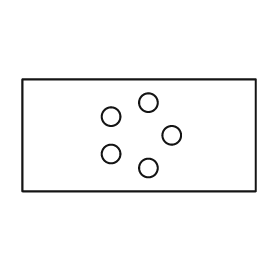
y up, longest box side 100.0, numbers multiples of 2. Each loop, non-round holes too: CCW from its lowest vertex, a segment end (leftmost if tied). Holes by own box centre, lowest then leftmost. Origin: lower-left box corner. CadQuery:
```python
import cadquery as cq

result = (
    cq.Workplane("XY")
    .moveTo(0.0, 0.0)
    .lineTo(100.0, 0.0)
    .lineTo(100.0, 48.0)
    .lineTo(0.0, 48.0)
    .close()
    .moveTo(54.0, 10.0)
    .circle(4.0)
    .moveTo(38.0, 16.0)
    .circle(4.0)
    .moveTo(64.0, 24.0)
    .circle(4.0)
    .moveTo(38.0, 32.0)
    .circle(4.0)
    .moveTo(54.0, 38.0)
    .circle(4.0)
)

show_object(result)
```